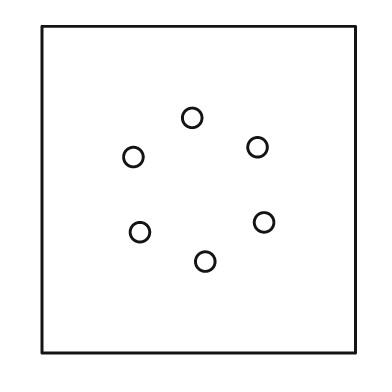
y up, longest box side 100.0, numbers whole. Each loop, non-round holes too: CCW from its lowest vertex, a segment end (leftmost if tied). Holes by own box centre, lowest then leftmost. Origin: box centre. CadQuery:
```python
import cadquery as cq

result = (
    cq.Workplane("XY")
    .moveTo(-48.0, -50.0)
    .lineTo(48.0, -50.0)
    .lineTo(48.0, 50.0)
    .lineTo(-48.0, 50.0)
    .close()
    .moveTo(2.0, -22.0)
    .circle(3.0)
    .moveTo(-18.0, -13.0)
    .circle(3.0)
    .moveTo(20.0, -10.0)
    .circle(3.0)
    .moveTo(-20.0, 10.0)
    .circle(3.0)
    .moveTo(18.0, 13.0)
    .circle(3.0)
    .moveTo(-2.0, 22.0)
    .circle(3.0)
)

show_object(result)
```